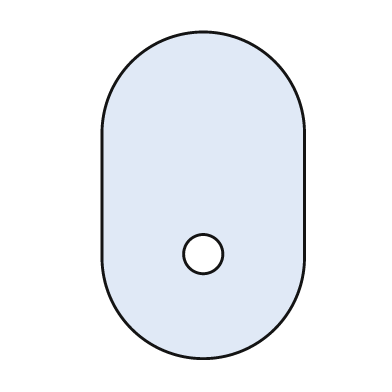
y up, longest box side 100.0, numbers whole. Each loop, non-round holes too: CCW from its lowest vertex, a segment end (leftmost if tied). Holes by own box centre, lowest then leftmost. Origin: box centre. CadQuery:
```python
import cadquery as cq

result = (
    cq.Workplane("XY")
    .moveTo(-31.0, -19.0)
    .threePointArc((0.0, -50.0), (31.0, -19.0))
    .lineTo(31.0, 19.0)
    .threePointArc((0.0, 50.0), (-31.0, 19.0))
    .close()
    .moveTo(0.0, -18.0)
    .circle(6.0)
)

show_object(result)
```